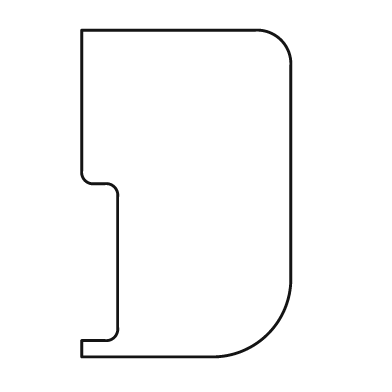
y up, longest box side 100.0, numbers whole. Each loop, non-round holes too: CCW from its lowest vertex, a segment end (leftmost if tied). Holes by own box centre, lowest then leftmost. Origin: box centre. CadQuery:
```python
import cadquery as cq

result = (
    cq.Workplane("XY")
    .moveTo(-32.0, -50.0)
    .lineTo(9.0, -50.0)
    .threePointArc((25.0, -43.0), (32.0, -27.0))
    .lineTo(32.0, 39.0)
    .threePointArc((29.0, 47.0), (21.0, 50.0))
    .lineTo(-32.0, 50.0)
    .lineTo(-32.0, 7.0)
    .threePointArc((-31.0, 4.0), (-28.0, 3.0))
    .lineTo(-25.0, 3.0)
    .threePointArc((-22.0, 2.0), (-21.0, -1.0))
    .lineTo(-21.0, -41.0)
    .threePointArc((-22.0, -44.0), (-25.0, -45.0))
    .lineTo(-32.0, -45.0)
    .close()
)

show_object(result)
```